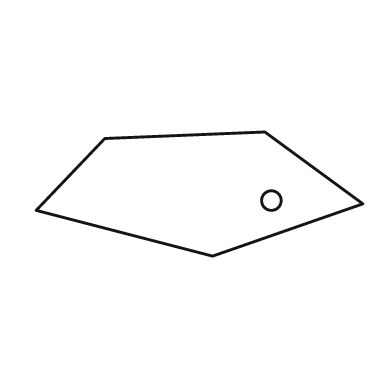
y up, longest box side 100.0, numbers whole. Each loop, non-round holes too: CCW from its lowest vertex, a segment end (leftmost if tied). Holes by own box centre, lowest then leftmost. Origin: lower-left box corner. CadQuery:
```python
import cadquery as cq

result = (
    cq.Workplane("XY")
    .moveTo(54.0, 0.0)
    .lineTo(100.0, 16.0)
    .lineTo(70.0, 38.0)
    .lineTo(21.0, 36.0)
    .lineTo(0.0, 14.0)
    .close()
    .moveTo(72.0, 17.0)
    .circle(3.0)
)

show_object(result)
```